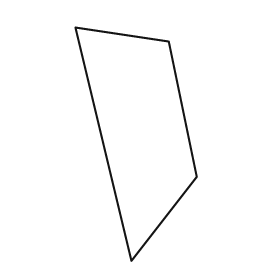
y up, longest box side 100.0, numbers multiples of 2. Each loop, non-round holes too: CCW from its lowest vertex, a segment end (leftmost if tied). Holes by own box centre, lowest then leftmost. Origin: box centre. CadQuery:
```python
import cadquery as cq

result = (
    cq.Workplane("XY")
    .moveTo(-2.0, -50.0)
    .lineTo(26.0, -14.0)
    .lineTo(14.0, 44.0)
    .lineTo(-26.0, 50.0)
    .close()
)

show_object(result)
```